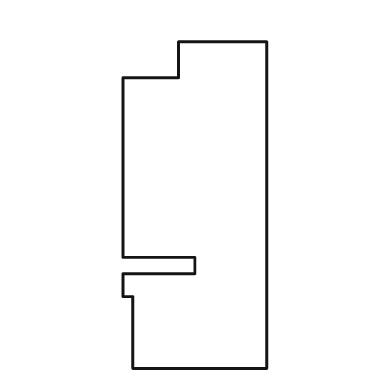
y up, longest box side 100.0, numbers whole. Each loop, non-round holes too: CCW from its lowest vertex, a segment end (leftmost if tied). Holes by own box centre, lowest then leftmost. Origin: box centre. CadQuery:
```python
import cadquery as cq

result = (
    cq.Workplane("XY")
    .moveTo(-19.0, -50.0)
    .lineTo(22.0, -50.0)
    .lineTo(22.0, 50.0)
    .lineTo(-5.0, 50.0)
    .lineTo(-5.0, 39.0)
    .lineTo(-22.0, 39.0)
    .lineTo(-22.0, -16.0)
    .lineTo(0.0, -16.0)
    .lineTo(0.0, -21.0)
    .lineTo(-22.0, -21.0)
    .lineTo(-22.0, -28.0)
    .lineTo(-19.0, -28.0)
    .close()
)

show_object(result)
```